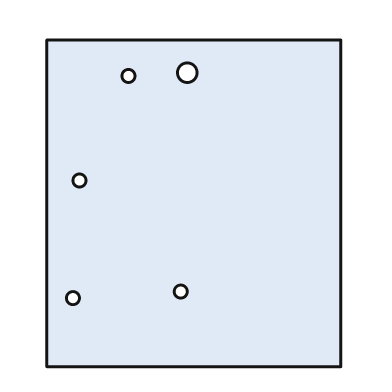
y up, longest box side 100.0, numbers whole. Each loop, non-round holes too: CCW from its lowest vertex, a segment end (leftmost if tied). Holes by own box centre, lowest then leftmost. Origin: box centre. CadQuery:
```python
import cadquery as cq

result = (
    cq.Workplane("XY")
    .moveTo(-45.0, -50.0)
    .lineTo(45.0, -50.0)
    .lineTo(45.0, 50.0)
    .lineTo(-45.0, 50.0)
    .close()
    .moveTo(-37.0, -29.0)
    .circle(2.0)
    .moveTo(-4.0, -27.0)
    .circle(2.0)
    .moveTo(-35.0, 7.0)
    .circle(2.0)
    .moveTo(-20.0, 39.0)
    .circle(2.0)
    .moveTo(-2.0, 40.0)
    .circle(3.0)
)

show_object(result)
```